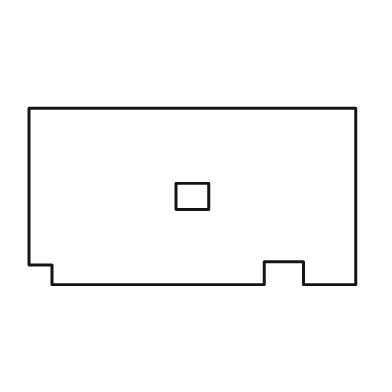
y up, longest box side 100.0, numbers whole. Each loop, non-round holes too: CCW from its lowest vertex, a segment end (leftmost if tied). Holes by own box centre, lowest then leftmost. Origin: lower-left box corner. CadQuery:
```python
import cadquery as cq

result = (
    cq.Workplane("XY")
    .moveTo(7.0, 0.0)
    .lineTo(72.0, 0.0)
    .lineTo(72.0, 7.0)
    .lineTo(84.0, 7.0)
    .lineTo(84.0, 0.0)
    .lineTo(100.0, 0.0)
    .lineTo(100.0, 54.0)
    .lineTo(0.0, 54.0)
    .lineTo(0.0, 6.0)
    .lineTo(7.0, 6.0)
    .close()
    .moveTo(45.0, 23.0)
    .lineTo(55.0, 23.0)
    .lineTo(55.0, 31.0)
    .lineTo(45.0, 31.0)
    .close()
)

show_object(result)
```